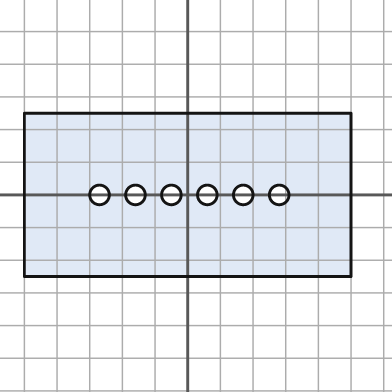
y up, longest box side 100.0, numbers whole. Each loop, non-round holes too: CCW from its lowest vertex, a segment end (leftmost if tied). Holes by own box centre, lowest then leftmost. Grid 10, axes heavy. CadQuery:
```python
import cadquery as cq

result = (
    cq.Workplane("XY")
    .moveTo(-50.0, -25.0)
    .lineTo(50.0, -25.0)
    .lineTo(50.0, 25.0)
    .lineTo(-50.0, 25.0)
    .close()
    .moveTo(-27.0, 0.0)
    .circle(3.0)
    .moveTo(-16.0, 0.0)
    .circle(3.0)
    .moveTo(-5.0, 0.0)
    .circle(3.0)
    .moveTo(6.0, 0.0)
    .circle(3.0)
    .moveTo(17.0, 0.0)
    .circle(3.0)
    .moveTo(28.0, 0.0)
    .circle(3.0)
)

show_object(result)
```